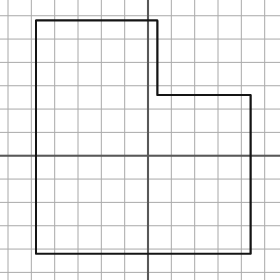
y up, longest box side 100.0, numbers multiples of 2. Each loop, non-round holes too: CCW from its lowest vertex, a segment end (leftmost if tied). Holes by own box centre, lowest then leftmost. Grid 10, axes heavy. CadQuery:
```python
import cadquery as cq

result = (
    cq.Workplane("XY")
    .moveTo(-48.0, -42.0)
    .lineTo(44.0, -42.0)
    .lineTo(44.0, 26.0)
    .lineTo(4.0, 26.0)
    .lineTo(4.0, 58.0)
    .lineTo(-48.0, 58.0)
    .close()
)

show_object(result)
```